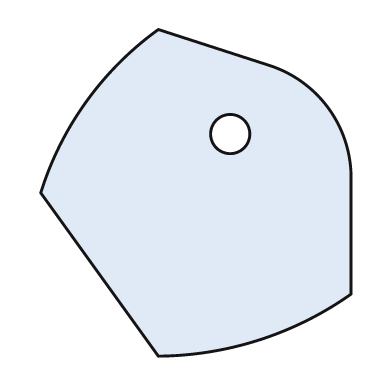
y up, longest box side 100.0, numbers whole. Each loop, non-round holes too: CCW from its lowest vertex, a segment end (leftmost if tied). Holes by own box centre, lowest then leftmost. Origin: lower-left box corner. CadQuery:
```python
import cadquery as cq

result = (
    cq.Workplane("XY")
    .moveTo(36.0, 0.0)
    .threePointArc((67.0, 5.0), (95.0, 19.0))
    .lineTo(95.0, 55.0)
    .threePointArc((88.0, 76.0), (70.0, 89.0))
    .lineTo(36.0, 100.0)
    .threePointArc((14.0, 78.0), (0.0, 50.0))
    .close()
    .moveTo(58.0, 68.0)
    .circle(6.0)
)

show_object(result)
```